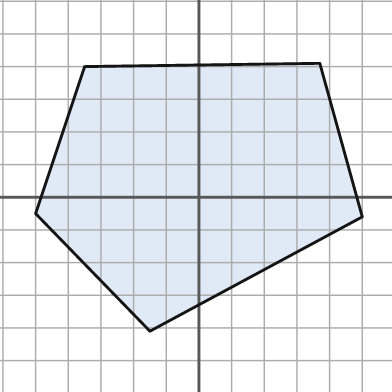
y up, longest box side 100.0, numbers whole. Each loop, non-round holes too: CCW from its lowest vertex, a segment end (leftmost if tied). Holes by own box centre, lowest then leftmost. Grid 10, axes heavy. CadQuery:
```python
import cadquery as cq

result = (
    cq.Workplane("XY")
    .moveTo(-15.0, -41.0)
    .lineTo(50.0, -6.0)
    .lineTo(37.0, 41.0)
    .lineTo(-35.0, 40.0)
    .lineTo(-50.0, -5.0)
    .close()
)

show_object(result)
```